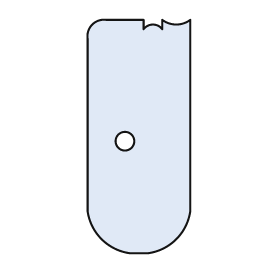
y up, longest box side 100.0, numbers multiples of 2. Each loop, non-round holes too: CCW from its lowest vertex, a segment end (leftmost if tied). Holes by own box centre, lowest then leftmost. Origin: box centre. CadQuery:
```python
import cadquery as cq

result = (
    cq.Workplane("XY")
    .moveTo(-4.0, -50.0)
    .lineTo(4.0, -50.0)
    .threePointArc((16.0, -44.0), (22.0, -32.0))
    .lineTo(22.0, 50.0)
    .threePointArc((16.0, 48.0), (10.0, 50.0))
    .lineTo(10.0, 46.0)
    .threePointArc((6.0, 48.0), (2.0, 46.0))
    .lineTo(2.0, 50.0)
    .lineTo(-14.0, 50.0)
    .threePointArc((-20.0, 48.0), (-22.0, 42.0))
    .lineTo(-22.0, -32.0)
    .threePointArc((-16.0, -44.0), (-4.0, -50.0))
    .close()
    .moveTo(-6.0, -2.0)
    .circle(4.0)
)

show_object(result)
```